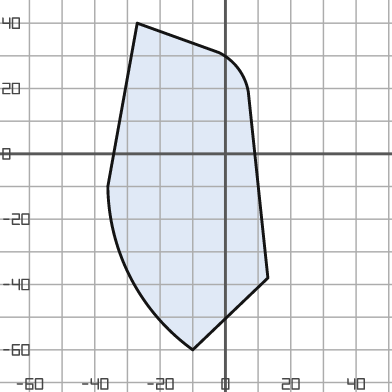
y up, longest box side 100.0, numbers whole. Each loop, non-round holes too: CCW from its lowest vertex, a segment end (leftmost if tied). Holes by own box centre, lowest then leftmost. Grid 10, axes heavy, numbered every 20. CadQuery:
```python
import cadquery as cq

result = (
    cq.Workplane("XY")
    .moveTo(-10.0, -60.0)
    .lineTo(13.0, -38.0)
    .lineTo(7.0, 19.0)
    .threePointArc((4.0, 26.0), (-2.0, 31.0))
    .lineTo(-27.0, 40.0)
    .lineTo(-36.0, -10.0)
    .threePointArc((-29.0, -38.0), (-10.0, -60.0))
    .close()
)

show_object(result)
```